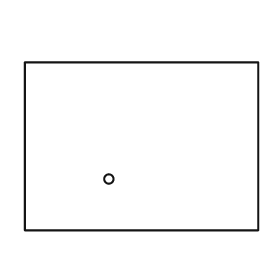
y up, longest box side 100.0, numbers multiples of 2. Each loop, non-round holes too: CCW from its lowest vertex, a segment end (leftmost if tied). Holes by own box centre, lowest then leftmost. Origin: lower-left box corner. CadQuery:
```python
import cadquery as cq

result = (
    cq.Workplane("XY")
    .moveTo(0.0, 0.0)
    .lineTo(100.0, 0.0)
    .lineTo(100.0, 72.0)
    .lineTo(0.0, 72.0)
    .close()
    .moveTo(36.0, 22.0)
    .circle(2.0)
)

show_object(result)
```